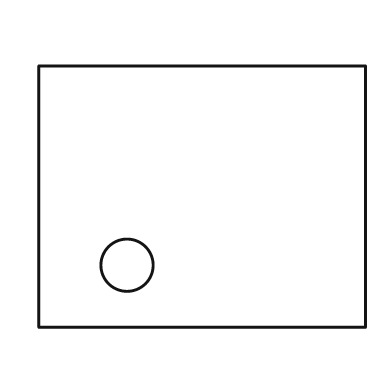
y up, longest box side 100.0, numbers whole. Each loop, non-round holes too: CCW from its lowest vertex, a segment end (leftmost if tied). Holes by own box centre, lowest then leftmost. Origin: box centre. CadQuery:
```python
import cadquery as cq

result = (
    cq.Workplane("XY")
    .moveTo(-50.0, -40.0)
    .lineTo(50.0, -40.0)
    .lineTo(50.0, 40.0)
    .lineTo(-50.0, 40.0)
    .close()
    .moveTo(-23.0, -21.0)
    .circle(8.0)
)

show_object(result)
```